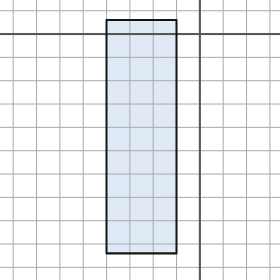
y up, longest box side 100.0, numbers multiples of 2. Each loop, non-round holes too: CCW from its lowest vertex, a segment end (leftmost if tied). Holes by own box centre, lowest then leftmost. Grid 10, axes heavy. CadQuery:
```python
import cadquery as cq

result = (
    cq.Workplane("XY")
    .moveTo(-40.0, -94.0)
    .lineTo(-10.0, -94.0)
    .lineTo(-10.0, 6.0)
    .lineTo(-40.0, 6.0)
    .close()
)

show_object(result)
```